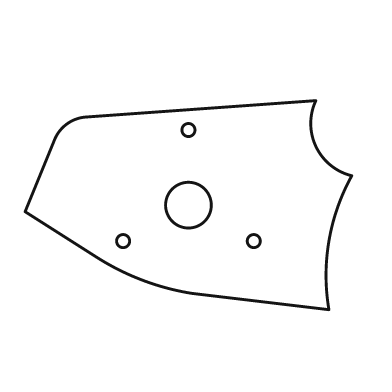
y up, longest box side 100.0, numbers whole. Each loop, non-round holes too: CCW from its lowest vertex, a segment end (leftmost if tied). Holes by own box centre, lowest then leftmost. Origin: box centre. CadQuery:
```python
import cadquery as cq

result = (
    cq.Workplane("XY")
    .moveTo(43.0, -32.0)
    .threePointArc((43.0, -11.0), (50.0, 9.0))
    .threePointArc((39.0, 18.0), (39.0, 32.0))
    .lineTo(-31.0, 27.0)
    .threePointArc((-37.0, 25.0), (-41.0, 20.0))
    .lineTo(-50.0, -2.0)
    .lineTo(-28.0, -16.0)
    .threePointArc((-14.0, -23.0), (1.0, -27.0))
    .close()
    .moveTo(-20.0, -11.0)
    .circle(2.0)
    .moveTo(20.0, -11.0)
    .circle(2.0)
    .moveTo(0.0, 0.0)
    .circle(7.0)
    .moveTo(0.0, 23.0)
    .circle(2.0)
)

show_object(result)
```